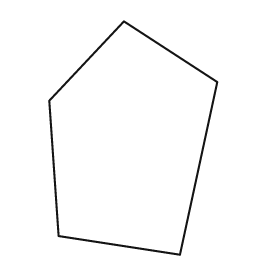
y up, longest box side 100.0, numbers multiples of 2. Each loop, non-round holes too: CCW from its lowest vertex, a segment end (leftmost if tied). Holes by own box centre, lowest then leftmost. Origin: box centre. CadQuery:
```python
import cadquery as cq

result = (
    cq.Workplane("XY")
    .moveTo(20.0, -50.0)
    .lineTo(36.0, 24.0)
    .lineTo(-4.0, 50.0)
    .lineTo(-36.0, 16.0)
    .lineTo(-32.0, -42.0)
    .close()
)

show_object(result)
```